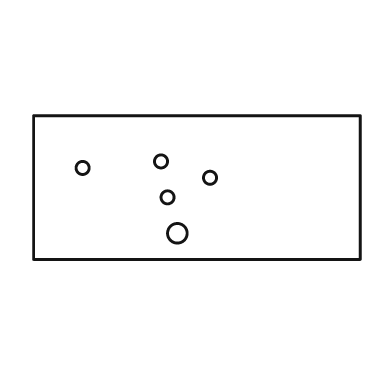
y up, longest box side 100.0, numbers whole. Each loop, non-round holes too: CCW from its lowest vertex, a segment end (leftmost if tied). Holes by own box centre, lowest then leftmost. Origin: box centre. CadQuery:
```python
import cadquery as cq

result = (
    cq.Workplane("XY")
    .moveTo(-50.0, -22.0)
    .lineTo(50.0, -22.0)
    .lineTo(50.0, 22.0)
    .lineTo(-50.0, 22.0)
    .close()
    .moveTo(-6.0, -14.0)
    .circle(3.0)
    .moveTo(-9.0, -3.0)
    .circle(2.0)
    .moveTo(4.0, 3.0)
    .circle(2.0)
    .moveTo(-35.0, 6.0)
    .circle(2.0)
    .moveTo(-11.0, 8.0)
    .circle(2.0)
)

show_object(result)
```